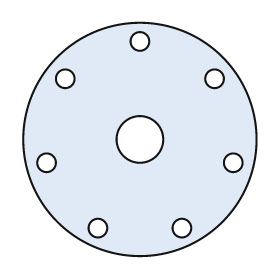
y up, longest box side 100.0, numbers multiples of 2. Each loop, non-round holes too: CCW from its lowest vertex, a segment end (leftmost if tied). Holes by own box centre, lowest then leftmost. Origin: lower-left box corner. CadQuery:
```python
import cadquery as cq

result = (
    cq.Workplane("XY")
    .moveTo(50.0, 50.0)
    .circle(50.0)
    .moveTo(32.0, 12.0)
    .circle(4.0)
    .moveTo(68.0, 12.0)
    .circle(4.0)
    .moveTo(10.0, 40.0)
    .circle(4.0)
    .moveTo(90.0, 40.0)
    .circle(4.0)
    .moveTo(50.0, 50.0)
    .circle(10.0)
    .moveTo(18.0, 76.0)
    .circle(4.0)
    .moveTo(82.0, 76.0)
    .circle(4.0)
    .moveTo(50.0, 92.0)
    .circle(4.0)
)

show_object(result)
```